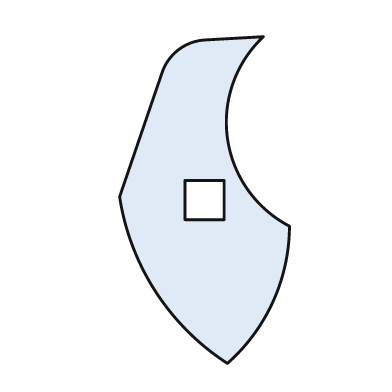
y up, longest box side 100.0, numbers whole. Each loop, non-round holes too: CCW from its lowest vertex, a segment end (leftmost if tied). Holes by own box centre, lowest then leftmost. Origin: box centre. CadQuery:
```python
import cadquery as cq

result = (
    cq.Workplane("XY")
    .moveTo(7.0, -50.0)
    .threePointArc((21.0, -31.0), (26.0, -8.0))
    .threePointArc((7.0, 19.0), (18.0, 50.0))
    .lineTo(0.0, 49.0)
    .threePointArc((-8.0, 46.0), (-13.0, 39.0))
    .lineTo(-26.0, 1.0)
    .threePointArc((-15.0, -28.0), (7.0, -50.0))
    .close()
    .moveTo(-6.0, -6.0)
    .lineTo(6.0, -6.0)
    .lineTo(6.0, 6.0)
    .lineTo(-6.0, 6.0)
    .close()
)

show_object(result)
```